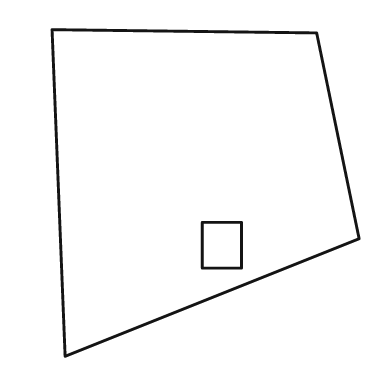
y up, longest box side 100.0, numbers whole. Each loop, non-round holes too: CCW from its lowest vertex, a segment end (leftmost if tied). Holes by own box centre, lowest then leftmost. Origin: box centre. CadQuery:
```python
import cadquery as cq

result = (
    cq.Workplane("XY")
    .moveTo(-43.0, -50.0)
    .lineTo(47.0, -14.0)
    .lineTo(34.0, 49.0)
    .lineTo(-47.0, 50.0)
    .close()
    .moveTo(-1.0, -23.0)
    .lineTo(11.0, -23.0)
    .lineTo(11.0, -9.0)
    .lineTo(-1.0, -9.0)
    .close()
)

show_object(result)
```